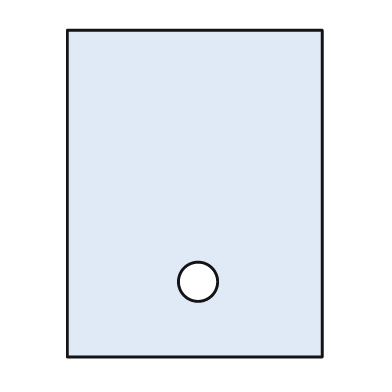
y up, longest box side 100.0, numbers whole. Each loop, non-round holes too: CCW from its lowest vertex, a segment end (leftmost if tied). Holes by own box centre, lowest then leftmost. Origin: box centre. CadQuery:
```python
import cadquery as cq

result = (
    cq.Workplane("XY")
    .moveTo(-39.0, -50.0)
    .lineTo(39.0, -50.0)
    .lineTo(39.0, 50.0)
    .lineTo(-39.0, 50.0)
    .close()
    .moveTo(1.0, -27.0)
    .circle(6.0)
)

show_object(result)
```